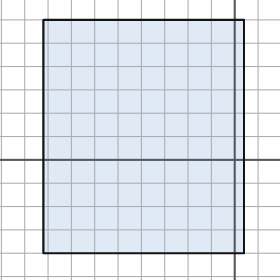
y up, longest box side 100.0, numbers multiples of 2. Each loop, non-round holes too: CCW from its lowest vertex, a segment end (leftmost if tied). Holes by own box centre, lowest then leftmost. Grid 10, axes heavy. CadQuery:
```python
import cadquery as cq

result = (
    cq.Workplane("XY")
    .moveTo(-82.0, -40.0)
    .lineTo(4.0, -40.0)
    .lineTo(4.0, 60.0)
    .lineTo(-82.0, 60.0)
    .close()
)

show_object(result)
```